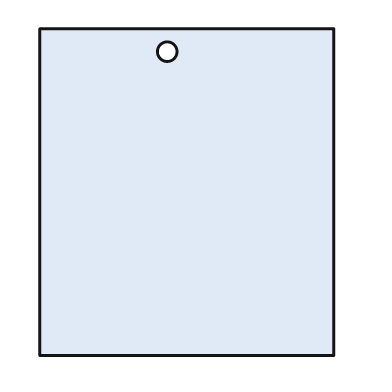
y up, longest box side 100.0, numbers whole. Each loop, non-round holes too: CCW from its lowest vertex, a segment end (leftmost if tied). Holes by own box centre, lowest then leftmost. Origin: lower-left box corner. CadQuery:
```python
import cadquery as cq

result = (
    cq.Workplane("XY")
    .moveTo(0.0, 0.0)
    .lineTo(90.0, 0.0)
    .lineTo(90.0, 100.0)
    .lineTo(0.0, 100.0)
    .close()
    .moveTo(39.0, 93.0)
    .circle(3.0)
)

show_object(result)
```